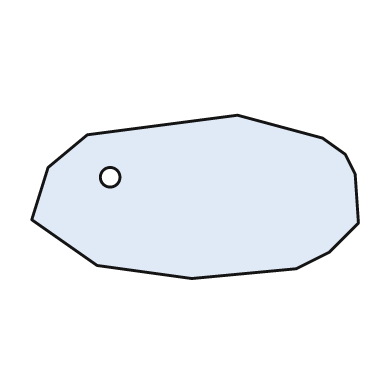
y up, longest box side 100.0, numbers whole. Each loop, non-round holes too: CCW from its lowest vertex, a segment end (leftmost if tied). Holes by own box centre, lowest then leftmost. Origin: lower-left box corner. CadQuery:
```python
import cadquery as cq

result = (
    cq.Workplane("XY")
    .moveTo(49.0, 0.0)
    .lineTo(81.0, 3.0)
    .lineTo(91.0, 8.0)
    .lineTo(100.0, 17.0)
    .lineTo(99.0, 32.0)
    .lineTo(96.0, 38.0)
    .lineTo(89.0, 43.0)
    .lineTo(63.0, 50.0)
    .lineTo(17.0, 44.0)
    .lineTo(5.0, 34.0)
    .lineTo(0.0, 18.0)
    .lineTo(20.0, 4.0)
    .close()
    .moveTo(24.0, 31.0)
    .circle(3.0)
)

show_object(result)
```